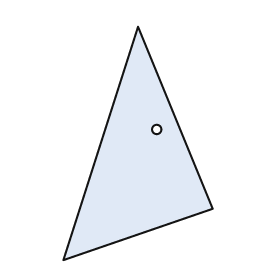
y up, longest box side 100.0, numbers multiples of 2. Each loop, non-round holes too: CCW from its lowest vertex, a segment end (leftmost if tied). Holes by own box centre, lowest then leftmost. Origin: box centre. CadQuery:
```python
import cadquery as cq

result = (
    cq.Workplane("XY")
    .moveTo(-32.0, -50.0)
    .lineTo(32.0, -28.0)
    .lineTo(0.0, 50.0)
    .close()
    .moveTo(8.0, 6.0)
    .circle(2.0)
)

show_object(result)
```